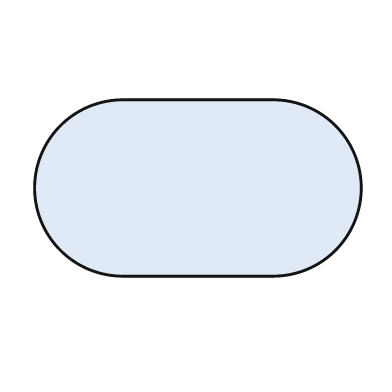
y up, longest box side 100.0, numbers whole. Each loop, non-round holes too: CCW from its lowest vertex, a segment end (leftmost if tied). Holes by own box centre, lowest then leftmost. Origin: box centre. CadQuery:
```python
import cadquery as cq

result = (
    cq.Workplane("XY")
    .moveTo(-23.0, -27.0)
    .lineTo(23.0, -27.0)
    .threePointArc((50.0, 0.0), (23.0, 27.0))
    .lineTo(-23.0, 27.0)
    .threePointArc((-50.0, 0.0), (-23.0, -27.0))
    .close()
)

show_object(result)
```